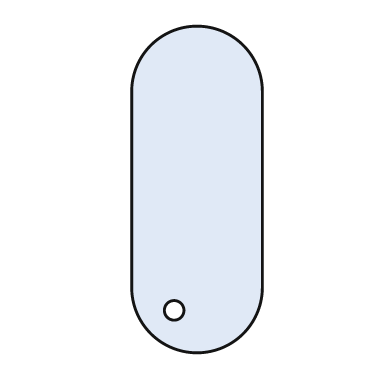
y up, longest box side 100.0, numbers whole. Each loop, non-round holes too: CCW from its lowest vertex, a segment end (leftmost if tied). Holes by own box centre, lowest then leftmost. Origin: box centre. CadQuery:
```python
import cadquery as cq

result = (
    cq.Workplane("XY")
    .moveTo(-20.0, -30.0)
    .threePointArc((0.0, -50.0), (20.0, -30.0))
    .lineTo(20.0, 30.0)
    .threePointArc((0.0, 50.0), (-20.0, 30.0))
    .close()
    .moveTo(-7.0, -37.0)
    .circle(3.0)
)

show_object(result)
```